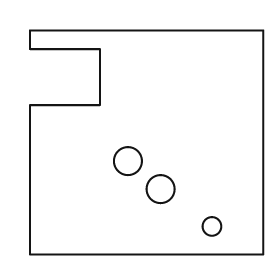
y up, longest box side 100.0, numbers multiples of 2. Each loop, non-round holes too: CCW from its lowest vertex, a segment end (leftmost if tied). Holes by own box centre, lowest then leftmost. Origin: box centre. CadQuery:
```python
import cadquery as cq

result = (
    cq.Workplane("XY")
    .moveTo(-50.0, -48.0)
    .lineTo(50.0, -48.0)
    .lineTo(50.0, 48.0)
    .lineTo(-50.0, 48.0)
    .lineTo(-50.0, 40.0)
    .lineTo(-20.0, 40.0)
    .lineTo(-20.0, 16.0)
    .lineTo(-50.0, 16.0)
    .close()
    .moveTo(28.0, -36.0)
    .circle(4.0)
    .moveTo(6.0, -20.0)
    .circle(6.0)
    .moveTo(-8.0, -8.0)
    .circle(6.0)
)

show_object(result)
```